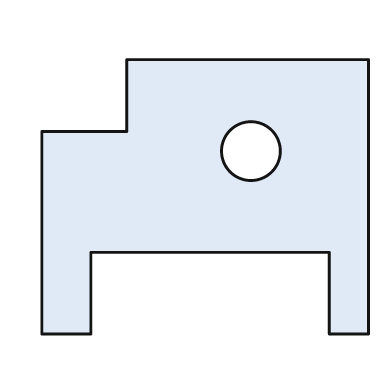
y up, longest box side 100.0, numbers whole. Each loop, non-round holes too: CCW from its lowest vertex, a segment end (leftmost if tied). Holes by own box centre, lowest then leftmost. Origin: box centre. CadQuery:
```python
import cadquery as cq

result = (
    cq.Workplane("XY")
    .moveTo(-50.0, -42.0)
    .lineTo(-35.0, -42.0)
    .lineTo(-35.0, -17.0)
    .lineTo(38.0, -17.0)
    .lineTo(38.0, -42.0)
    .lineTo(50.0, -42.0)
    .lineTo(50.0, 42.0)
    .lineTo(-24.0, 42.0)
    .lineTo(-24.0, 20.0)
    .lineTo(-50.0, 20.0)
    .close()
    .moveTo(14.0, 14.0)
    .circle(9.0)
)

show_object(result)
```